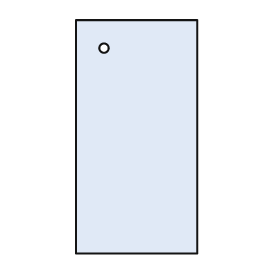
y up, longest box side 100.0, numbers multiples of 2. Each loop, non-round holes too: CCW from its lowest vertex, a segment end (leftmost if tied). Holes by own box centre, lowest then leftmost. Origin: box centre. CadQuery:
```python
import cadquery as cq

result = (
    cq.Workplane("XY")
    .moveTo(-26.0, -50.0)
    .lineTo(26.0, -50.0)
    .lineTo(26.0, 50.0)
    .lineTo(-26.0, 50.0)
    .close()
    .moveTo(-14.0, 38.0)
    .circle(2.0)
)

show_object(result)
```